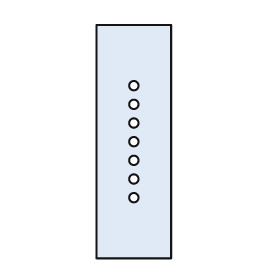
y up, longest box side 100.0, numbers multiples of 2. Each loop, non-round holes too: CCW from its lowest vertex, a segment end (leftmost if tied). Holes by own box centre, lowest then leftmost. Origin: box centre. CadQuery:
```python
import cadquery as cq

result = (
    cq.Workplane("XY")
    .moveTo(-16.0, -50.0)
    .lineTo(16.0, -50.0)
    .lineTo(16.0, 50.0)
    .lineTo(-16.0, 50.0)
    .close()
    .moveTo(0.0, -24.0)
    .circle(2.0)
    .moveTo(0.0, -16.0)
    .circle(2.0)
    .moveTo(0.0, -8.0)
    .circle(2.0)
    .moveTo(0.0, 0.0)
    .circle(2.0)
    .moveTo(0.0, 8.0)
    .circle(2.0)
    .moveTo(0.0, 16.0)
    .circle(2.0)
    .moveTo(0.0, 24.0)
    .circle(2.0)
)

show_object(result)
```